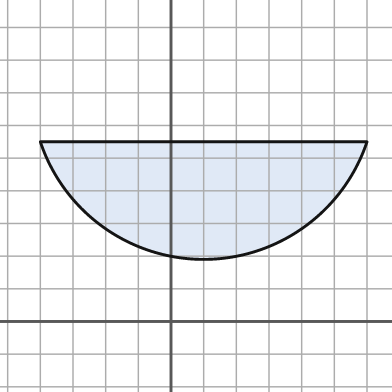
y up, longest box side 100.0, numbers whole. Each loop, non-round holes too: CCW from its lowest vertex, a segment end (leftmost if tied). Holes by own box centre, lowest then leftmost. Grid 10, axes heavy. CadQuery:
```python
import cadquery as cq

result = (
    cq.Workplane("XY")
    .moveTo(-40.0, 55.0)
    .threePointArc((10.0, 19.0), (60.0, 55.0))
    .close()
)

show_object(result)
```